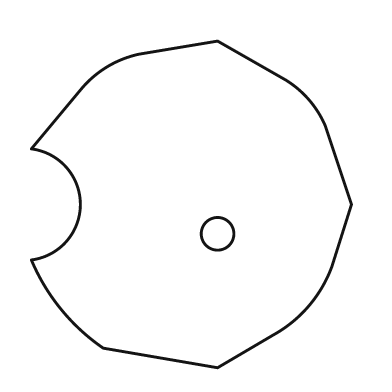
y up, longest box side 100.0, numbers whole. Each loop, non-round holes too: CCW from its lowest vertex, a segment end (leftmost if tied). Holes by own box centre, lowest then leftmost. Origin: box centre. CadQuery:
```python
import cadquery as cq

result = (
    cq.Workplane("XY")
    .moveTo(8.0, -50.0)
    .lineTo(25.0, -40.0)
    .threePointArc((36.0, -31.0), (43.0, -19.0))
    .lineTo(49.0, 0.0)
    .lineTo(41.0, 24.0)
    .threePointArc((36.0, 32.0), (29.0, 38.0))
    .lineTo(8.0, 50.0)
    .lineTo(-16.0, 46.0)
    .threePointArc((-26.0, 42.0), (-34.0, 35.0))
    .lineTo(-49.0, 17.0)
    .threePointArc((-34.0, 0.0), (-49.0, -17.0))
    .threePointArc((-40.0, -32.0), (-27.0, -44.0))
    .close()
    .moveTo(8.0, -9.0)
    .circle(5.0)
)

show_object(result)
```